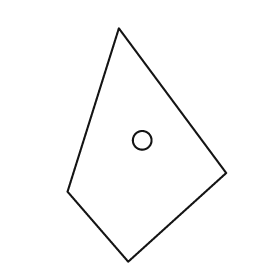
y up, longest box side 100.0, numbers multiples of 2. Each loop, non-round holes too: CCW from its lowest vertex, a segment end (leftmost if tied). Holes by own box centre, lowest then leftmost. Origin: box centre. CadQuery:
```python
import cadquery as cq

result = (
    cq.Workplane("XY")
    .moveTo(-8.0, -50.0)
    .lineTo(34.0, -12.0)
    .lineTo(-12.0, 50.0)
    .lineTo(-34.0, -20.0)
    .close()
    .moveTo(-2.0, 2.0)
    .circle(4.0)
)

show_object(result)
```